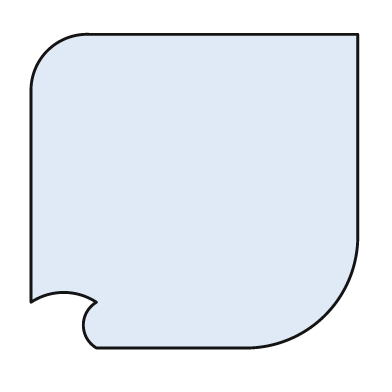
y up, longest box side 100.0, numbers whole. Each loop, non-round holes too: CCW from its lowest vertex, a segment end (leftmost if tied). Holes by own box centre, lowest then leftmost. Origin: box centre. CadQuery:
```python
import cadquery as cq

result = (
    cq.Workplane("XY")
    .moveTo(-30.0, -48.0)
    .lineTo(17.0, -48.0)
    .threePointArc((40.0, -38.0), (50.0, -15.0))
    .lineTo(50.0, 48.0)
    .lineTo(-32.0, 48.0)
    .threePointArc((-45.0, 43.0), (-50.0, 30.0))
    .lineTo(-50.0, -34.0)
    .threePointArc((-40.0, -31.0), (-30.0, -34.0))
    .threePointArc((-34.0, -41.0), (-30.0, -48.0))
    .close()
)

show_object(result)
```